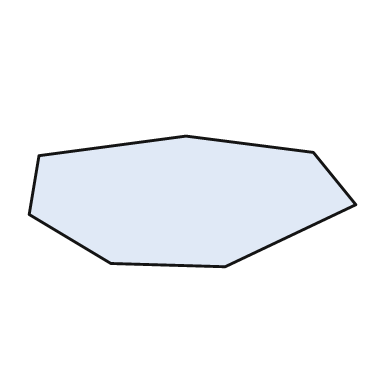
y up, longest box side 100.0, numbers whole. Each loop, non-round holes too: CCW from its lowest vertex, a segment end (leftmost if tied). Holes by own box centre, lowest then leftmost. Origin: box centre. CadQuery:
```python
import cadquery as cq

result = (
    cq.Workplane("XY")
    .moveTo(10.0, -20.0)
    .lineTo(50.0, -1.0)
    .lineTo(37.0, 15.0)
    .lineTo(-2.0, 20.0)
    .lineTo(-47.0, 14.0)
    .lineTo(-50.0, -4.0)
    .lineTo(-25.0, -19.0)
    .close()
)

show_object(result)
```